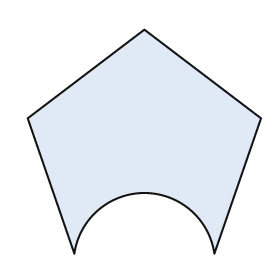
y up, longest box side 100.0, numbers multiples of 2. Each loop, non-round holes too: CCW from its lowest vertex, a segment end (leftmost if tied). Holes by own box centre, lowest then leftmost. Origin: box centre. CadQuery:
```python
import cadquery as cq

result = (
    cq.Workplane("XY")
    .moveTo(-30.0, -48.0)
    .threePointArc((0.0, -22.0), (30.0, -48.0))
    .lineTo(50.0, 10.0)
    .lineTo(0.0, 48.0)
    .lineTo(-50.0, 10.0)
    .close()
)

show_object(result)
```